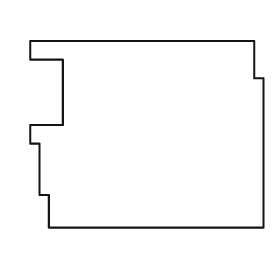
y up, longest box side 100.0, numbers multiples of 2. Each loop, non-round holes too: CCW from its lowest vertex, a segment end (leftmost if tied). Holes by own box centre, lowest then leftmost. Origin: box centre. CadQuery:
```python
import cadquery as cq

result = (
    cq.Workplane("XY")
    .moveTo(-42.0, -40.0)
    .lineTo(50.0, -40.0)
    .lineTo(50.0, 24.0)
    .lineTo(46.0, 24.0)
    .lineTo(46.0, 40.0)
    .lineTo(-50.0, 40.0)
    .lineTo(-50.0, 32.0)
    .lineTo(-36.0, 32.0)
    .lineTo(-36.0, 4.0)
    .lineTo(-50.0, 4.0)
    .lineTo(-50.0, -4.0)
    .lineTo(-46.0, -4.0)
    .lineTo(-46.0, -26.0)
    .lineTo(-42.0, -26.0)
    .close()
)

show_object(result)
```